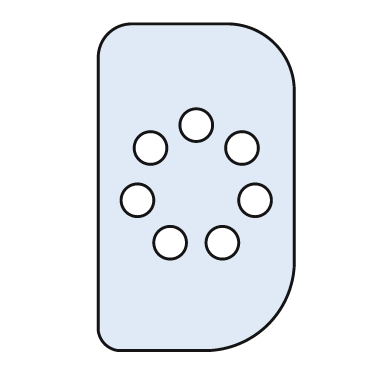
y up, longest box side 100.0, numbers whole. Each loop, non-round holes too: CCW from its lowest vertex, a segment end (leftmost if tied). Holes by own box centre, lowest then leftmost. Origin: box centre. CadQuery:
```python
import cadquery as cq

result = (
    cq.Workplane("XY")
    .moveTo(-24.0, -50.0)
    .lineTo(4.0, -50.0)
    .threePointArc((22.0, -42.0), (30.0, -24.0))
    .lineTo(30.0, 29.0)
    .threePointArc((24.0, 44.0), (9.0, 50.0))
    .lineTo(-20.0, 50.0)
    .threePointArc((-27.0, 47.0), (-30.0, 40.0))
    .lineTo(-30.0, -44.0)
    .threePointArc((-28.0, -48.0), (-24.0, -50.0))
    .close()
    .moveTo(-8.0, -17.0)
    .circle(5.0)
    .moveTo(8.0, -17.0)
    .circle(5.0)
    .moveTo(-18.0, -4.0)
    .circle(5.0)
    .moveTo(18.0, -4.0)
    .circle(5.0)
    .moveTo(-14.0, 12.0)
    .circle(5.0)
    .moveTo(14.0, 12.0)
    .circle(5.0)
    .moveTo(0.0, 19.0)
    .circle(5.0)
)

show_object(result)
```